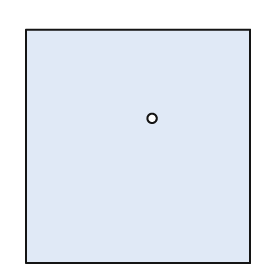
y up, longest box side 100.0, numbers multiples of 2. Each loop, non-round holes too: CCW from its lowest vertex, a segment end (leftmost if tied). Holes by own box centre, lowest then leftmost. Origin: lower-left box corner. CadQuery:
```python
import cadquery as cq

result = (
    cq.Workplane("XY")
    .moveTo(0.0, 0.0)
    .lineTo(96.0, 0.0)
    .lineTo(96.0, 100.0)
    .lineTo(0.0, 100.0)
    .close()
    .moveTo(54.0, 62.0)
    .circle(2.0)
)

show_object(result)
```